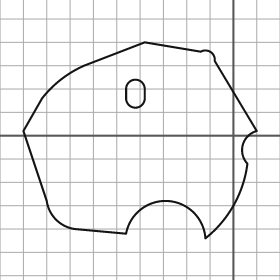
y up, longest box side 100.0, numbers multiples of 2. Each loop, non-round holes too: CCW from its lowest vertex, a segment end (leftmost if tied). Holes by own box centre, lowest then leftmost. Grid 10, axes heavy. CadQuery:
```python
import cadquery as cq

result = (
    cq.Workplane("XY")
    .moveTo(-12.0, -44.0)
    .threePointArc((0.0, -30.0), (6.0, -12.0))
    .threePointArc((4.0, -4.0), (10.0, 2.0))
    .lineTo(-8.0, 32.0)
    .threePointArc((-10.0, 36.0), (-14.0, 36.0))
    .lineTo(-38.0, 40.0)
    .lineTo(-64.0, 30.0)
    .threePointArc((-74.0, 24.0), (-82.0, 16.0))
    .lineTo(-90.0, 2.0)
    .lineTo(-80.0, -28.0)
    .threePointArc((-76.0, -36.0), (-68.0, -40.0))
    .lineTo(-46.0, -42.0)
    .threePointArc((-28.0, -28.0), (-12.0, -44.0))
    .close()
    .moveTo(-46.0, 16.0)
    .threePointArc((-42.0, 12.0), (-38.0, 16.0))
    .lineTo(-38.0, 20.0)
    .threePointArc((-42.0, 24.0), (-46.0, 20.0))
    .close()
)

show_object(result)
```